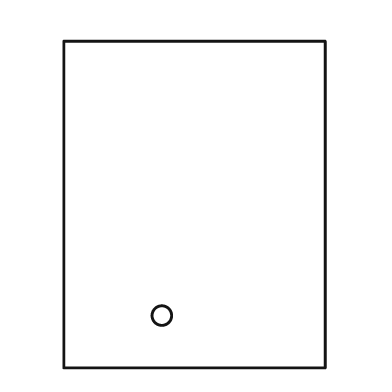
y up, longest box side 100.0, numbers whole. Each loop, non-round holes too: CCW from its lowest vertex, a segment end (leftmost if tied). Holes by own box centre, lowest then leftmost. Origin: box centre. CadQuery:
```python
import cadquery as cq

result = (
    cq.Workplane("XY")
    .moveTo(-40.0, -50.0)
    .lineTo(40.0, -50.0)
    .lineTo(40.0, 50.0)
    .lineTo(-40.0, 50.0)
    .close()
    .moveTo(-10.0, -34.0)
    .circle(3.0)
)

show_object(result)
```